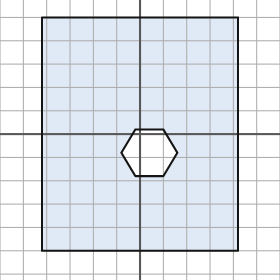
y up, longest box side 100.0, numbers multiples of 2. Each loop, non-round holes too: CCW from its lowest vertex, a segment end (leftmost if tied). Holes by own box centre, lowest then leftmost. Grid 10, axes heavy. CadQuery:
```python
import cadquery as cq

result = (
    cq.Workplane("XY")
    .moveTo(-42.0, -50.0)
    .lineTo(42.0, -50.0)
    .lineTo(42.0, 50.0)
    .lineTo(-42.0, 50.0)
    .close()
    .moveTo(-2.0, -18.0)
    .lineTo(10.0, -18.0)
    .lineTo(16.0, -8.0)
    .lineTo(10.0, 2.0)
    .lineTo(-2.0, 2.0)
    .lineTo(-8.0, -8.0)
    .close()
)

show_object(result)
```